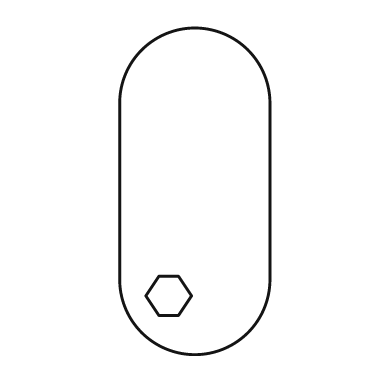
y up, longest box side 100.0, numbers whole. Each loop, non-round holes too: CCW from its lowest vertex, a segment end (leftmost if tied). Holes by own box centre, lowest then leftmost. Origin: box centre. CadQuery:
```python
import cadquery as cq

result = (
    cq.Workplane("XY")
    .moveTo(-23.0, -27.0)
    .threePointArc((0.0, -50.0), (23.0, -27.0))
    .lineTo(23.0, 27.0)
    .threePointArc((0.0, 50.0), (-23.0, 27.0))
    .close()
    .moveTo(-11.0, -38.0)
    .lineTo(-5.0, -38.0)
    .lineTo(-1.0, -32.0)
    .lineTo(-5.0, -26.0)
    .lineTo(-11.0, -26.0)
    .lineTo(-15.0, -32.0)
    .close()
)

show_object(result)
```